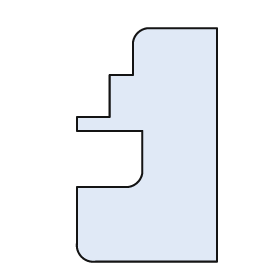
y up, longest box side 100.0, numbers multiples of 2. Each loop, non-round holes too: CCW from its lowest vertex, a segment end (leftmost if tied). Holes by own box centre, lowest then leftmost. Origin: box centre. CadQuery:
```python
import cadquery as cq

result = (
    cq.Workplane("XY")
    .moveTo(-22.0, -50.0)
    .lineTo(30.0, -50.0)
    .lineTo(30.0, 50.0)
    .lineTo(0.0, 50.0)
    .threePointArc((-4.0, 48.0), (-6.0, 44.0))
    .lineTo(-6.0, 30.0)
    .lineTo(-16.0, 30.0)
    .lineTo(-16.0, 12.0)
    .lineTo(-30.0, 12.0)
    .lineTo(-30.0, 6.0)
    .lineTo(-2.0, 6.0)
    .lineTo(-2.0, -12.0)
    .threePointArc((-4.0, -16.0), (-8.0, -18.0))
    .lineTo(-30.0, -18.0)
    .lineTo(-30.0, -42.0)
    .threePointArc((-28.0, -48.0), (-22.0, -50.0))
    .close()
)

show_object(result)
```